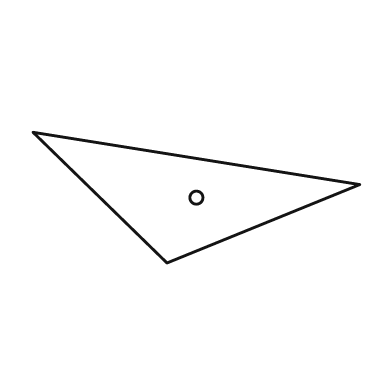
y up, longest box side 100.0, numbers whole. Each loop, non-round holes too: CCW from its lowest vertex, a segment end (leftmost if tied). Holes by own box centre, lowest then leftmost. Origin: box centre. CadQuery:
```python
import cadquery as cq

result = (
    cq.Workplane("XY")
    .moveTo(-9.0, -20.0)
    .lineTo(50.0, 4.0)
    .lineTo(-50.0, 20.0)
    .close()
    .moveTo(0.0, 0.0)
    .circle(2.0)
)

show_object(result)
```